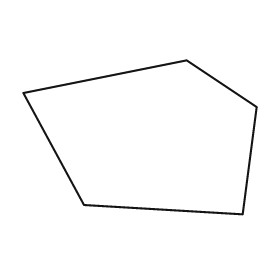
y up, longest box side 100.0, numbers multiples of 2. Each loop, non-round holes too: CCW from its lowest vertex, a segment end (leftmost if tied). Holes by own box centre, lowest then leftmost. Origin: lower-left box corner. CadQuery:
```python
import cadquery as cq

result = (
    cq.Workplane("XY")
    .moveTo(94.0, 0.0)
    .lineTo(100.0, 46.0)
    .lineTo(70.0, 66.0)
    .lineTo(0.0, 52.0)
    .lineTo(26.0, 4.0)
    .close()
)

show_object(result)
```